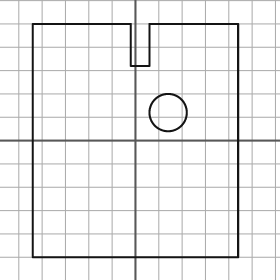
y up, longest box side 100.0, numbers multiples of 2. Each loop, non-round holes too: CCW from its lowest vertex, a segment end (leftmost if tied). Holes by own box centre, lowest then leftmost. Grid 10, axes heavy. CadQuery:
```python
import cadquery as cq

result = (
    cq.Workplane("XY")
    .moveTo(-44.0, -50.0)
    .lineTo(44.0, -50.0)
    .lineTo(44.0, 50.0)
    .lineTo(6.0, 50.0)
    .lineTo(6.0, 32.0)
    .lineTo(-2.0, 32.0)
    .lineTo(-2.0, 50.0)
    .lineTo(-44.0, 50.0)
    .close()
    .moveTo(14.0, 12.0)
    .circle(8.0)
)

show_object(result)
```